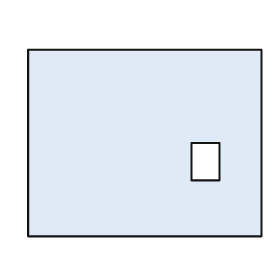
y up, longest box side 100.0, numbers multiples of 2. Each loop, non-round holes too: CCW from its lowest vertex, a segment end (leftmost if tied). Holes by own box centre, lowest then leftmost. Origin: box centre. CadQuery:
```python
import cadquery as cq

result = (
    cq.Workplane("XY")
    .moveTo(-50.0, -40.0)
    .lineTo(50.0, -40.0)
    .lineTo(50.0, 40.0)
    .lineTo(-50.0, 40.0)
    .close()
    .moveTo(20.0, -16.0)
    .lineTo(32.0, -16.0)
    .lineTo(32.0, 0.0)
    .lineTo(20.0, 0.0)
    .close()
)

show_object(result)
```